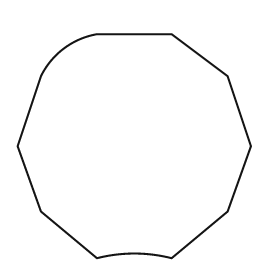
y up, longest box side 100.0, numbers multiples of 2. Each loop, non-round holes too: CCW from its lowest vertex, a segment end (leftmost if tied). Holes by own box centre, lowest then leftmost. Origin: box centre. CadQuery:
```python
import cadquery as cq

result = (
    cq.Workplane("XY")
    .moveTo(-16.0, -48.0)
    .threePointArc((0.0, -46.0), (16.0, -48.0))
    .lineTo(40.0, -28.0)
    .lineTo(50.0, 0.0)
    .lineTo(40.0, 30.0)
    .lineTo(16.0, 48.0)
    .lineTo(-16.0, 48.0)
    .threePointArc((-30.0, 42.0), (-40.0, 30.0))
    .lineTo(-50.0, 0.0)
    .lineTo(-40.0, -28.0)
    .close()
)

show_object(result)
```